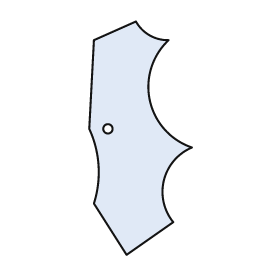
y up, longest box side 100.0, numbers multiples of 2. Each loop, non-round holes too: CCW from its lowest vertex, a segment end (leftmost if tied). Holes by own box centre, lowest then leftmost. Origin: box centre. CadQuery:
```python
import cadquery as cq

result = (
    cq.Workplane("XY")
    .moveTo(-6.0, -50.0)
    .lineTo(14.0, -36.0)
    .threePointArc((10.0, -18.0), (22.0, -4.0))
    .threePointArc((4.0, 16.0), (12.0, 42.0))
    .threePointArc((4.0, 44.0), (-2.0, 50.0))
    .lineTo(-20.0, 42.0)
    .lineTo(-22.0, 4.0)
    .threePointArc((-18.0, -12.0), (-20.0, -28.0))
    .close()
    .moveTo(-14.0, 4.0)
    .circle(2.0)
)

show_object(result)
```